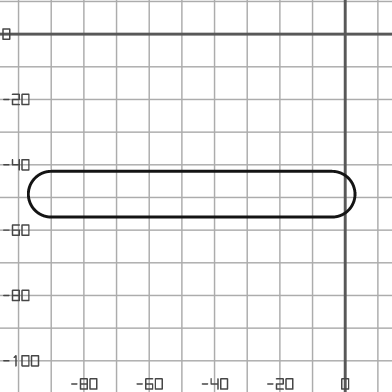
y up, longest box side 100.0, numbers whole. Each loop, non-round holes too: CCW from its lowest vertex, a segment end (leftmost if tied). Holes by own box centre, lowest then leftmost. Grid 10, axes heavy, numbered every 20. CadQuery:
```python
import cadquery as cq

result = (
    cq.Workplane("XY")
    .moveTo(-90.0, -56.0)
    .lineTo(-4.0, -56.0)
    .threePointArc((3.0, -49.0), (-4.0, -42.0))
    .lineTo(-90.0, -42.0)
    .threePointArc((-97.0, -49.0), (-90.0, -56.0))
    .close()
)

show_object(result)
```